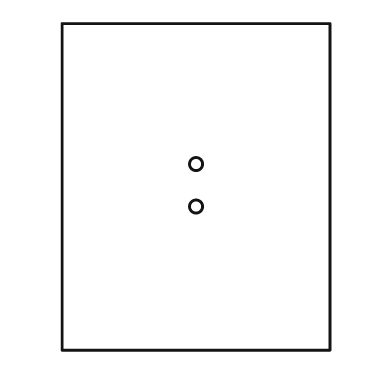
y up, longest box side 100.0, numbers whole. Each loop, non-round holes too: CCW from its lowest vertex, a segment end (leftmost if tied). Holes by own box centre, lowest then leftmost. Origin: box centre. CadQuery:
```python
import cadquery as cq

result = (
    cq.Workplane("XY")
    .moveTo(-41.0, -50.0)
    .lineTo(41.0, -50.0)
    .lineTo(41.0, 50.0)
    .lineTo(-41.0, 50.0)
    .close()
    .moveTo(0.0, -6.0)
    .circle(2.0)
    .moveTo(0.0, 7.0)
    .circle(2.0)
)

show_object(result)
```